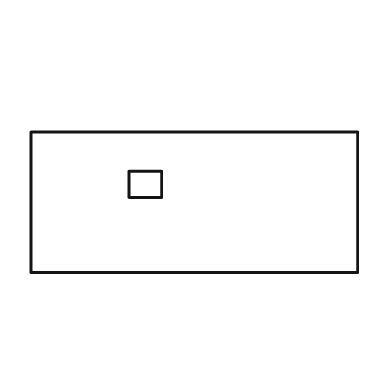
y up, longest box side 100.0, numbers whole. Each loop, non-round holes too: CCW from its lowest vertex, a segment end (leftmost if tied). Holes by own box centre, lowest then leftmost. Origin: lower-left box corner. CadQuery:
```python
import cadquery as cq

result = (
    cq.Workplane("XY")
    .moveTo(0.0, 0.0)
    .lineTo(100.0, 0.0)
    .lineTo(100.0, 43.0)
    .lineTo(0.0, 43.0)
    .close()
    .moveTo(30.0, 23.0)
    .lineTo(40.0, 23.0)
    .lineTo(40.0, 31.0)
    .lineTo(30.0, 31.0)
    .close()
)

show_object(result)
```